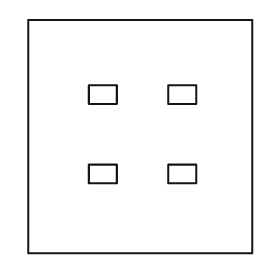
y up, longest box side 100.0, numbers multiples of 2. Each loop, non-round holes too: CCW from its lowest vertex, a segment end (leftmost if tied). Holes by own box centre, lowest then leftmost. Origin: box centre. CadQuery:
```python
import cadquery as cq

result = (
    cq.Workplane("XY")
    .moveTo(-48.0, -50.0)
    .lineTo(48.0, -50.0)
    .lineTo(48.0, 50.0)
    .lineTo(-48.0, 50.0)
    .close()
    .moveTo(-22.0, -20.0)
    .lineTo(-10.0, -20.0)
    .lineTo(-10.0, -12.0)
    .lineTo(-22.0, -12.0)
    .close()
    .moveTo(12.0, -20.0)
    .lineTo(24.0, -20.0)
    .lineTo(24.0, -12.0)
    .lineTo(12.0, -12.0)
    .close()
    .moveTo(-22.0, 14.0)
    .lineTo(-10.0, 14.0)
    .lineTo(-10.0, 22.0)
    .lineTo(-22.0, 22.0)
    .close()
    .moveTo(12.0, 14.0)
    .lineTo(24.0, 14.0)
    .lineTo(24.0, 22.0)
    .lineTo(12.0, 22.0)
    .close()
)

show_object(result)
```